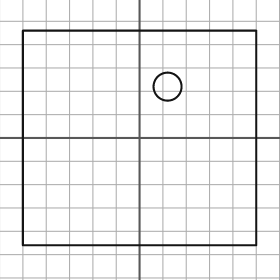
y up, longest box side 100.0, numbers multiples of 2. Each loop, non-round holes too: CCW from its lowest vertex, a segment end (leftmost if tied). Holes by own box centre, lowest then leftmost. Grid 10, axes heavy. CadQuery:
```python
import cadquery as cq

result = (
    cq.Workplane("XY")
    .moveTo(-50.0, -46.0)
    .lineTo(50.0, -46.0)
    .lineTo(50.0, 46.0)
    .lineTo(-50.0, 46.0)
    .close()
    .moveTo(12.0, 22.0)
    .circle(6.0)
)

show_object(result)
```